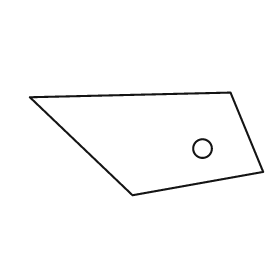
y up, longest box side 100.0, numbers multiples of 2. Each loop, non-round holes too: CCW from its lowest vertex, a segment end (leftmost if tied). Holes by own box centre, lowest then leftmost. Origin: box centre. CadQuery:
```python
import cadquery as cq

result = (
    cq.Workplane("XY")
    .moveTo(-6.0, -22.0)
    .lineTo(50.0, -12.0)
    .lineTo(36.0, 22.0)
    .lineTo(-50.0, 20.0)
    .close()
    .moveTo(24.0, -2.0)
    .circle(4.0)
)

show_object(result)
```